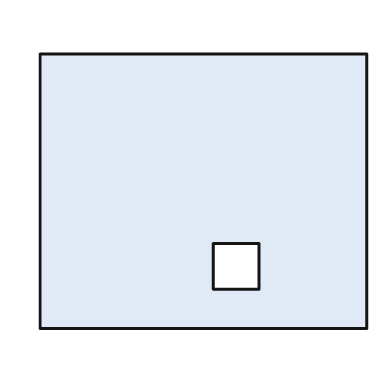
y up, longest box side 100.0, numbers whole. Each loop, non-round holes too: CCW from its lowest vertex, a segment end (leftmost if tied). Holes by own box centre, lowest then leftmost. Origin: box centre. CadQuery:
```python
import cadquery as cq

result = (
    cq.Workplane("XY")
    .moveTo(-50.0, -42.0)
    .lineTo(50.0, -42.0)
    .lineTo(50.0, 42.0)
    .lineTo(-50.0, 42.0)
    .close()
    .moveTo(3.0, -30.0)
    .lineTo(17.0, -30.0)
    .lineTo(17.0, -16.0)
    .lineTo(3.0, -16.0)
    .close()
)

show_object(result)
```